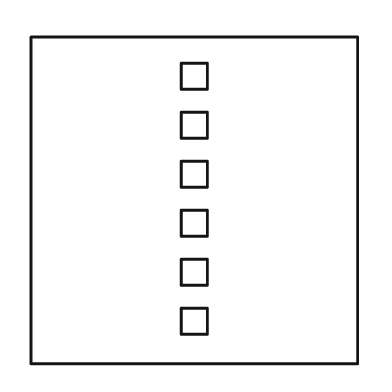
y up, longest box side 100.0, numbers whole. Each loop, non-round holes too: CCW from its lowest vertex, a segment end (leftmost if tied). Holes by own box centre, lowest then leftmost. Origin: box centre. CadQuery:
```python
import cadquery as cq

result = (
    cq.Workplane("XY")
    .moveTo(-50.0, -50.0)
    .lineTo(50.0, -50.0)
    .lineTo(50.0, 50.0)
    .lineTo(-50.0, 50.0)
    .close()
    .moveTo(-4.0, -41.0)
    .lineTo(4.0, -41.0)
    .lineTo(4.0, -33.0)
    .lineTo(-4.0, -33.0)
    .close()
    .moveTo(-4.0, -26.0)
    .lineTo(4.0, -26.0)
    .lineTo(4.0, -18.0)
    .lineTo(-4.0, -18.0)
    .close()
    .moveTo(-4.0, -11.0)
    .lineTo(4.0, -11.0)
    .lineTo(4.0, -3.0)
    .lineTo(-4.0, -3.0)
    .close()
    .moveTo(-4.0, 4.0)
    .lineTo(4.0, 4.0)
    .lineTo(4.0, 12.0)
    .lineTo(-4.0, 12.0)
    .close()
    .moveTo(-4.0, 19.0)
    .lineTo(4.0, 19.0)
    .lineTo(4.0, 27.0)
    .lineTo(-4.0, 27.0)
    .close()
    .moveTo(-4.0, 34.0)
    .lineTo(4.0, 34.0)
    .lineTo(4.0, 42.0)
    .lineTo(-4.0, 42.0)
    .close()
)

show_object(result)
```